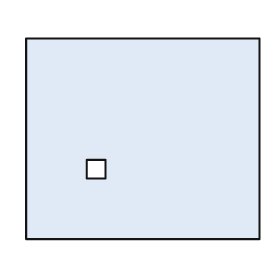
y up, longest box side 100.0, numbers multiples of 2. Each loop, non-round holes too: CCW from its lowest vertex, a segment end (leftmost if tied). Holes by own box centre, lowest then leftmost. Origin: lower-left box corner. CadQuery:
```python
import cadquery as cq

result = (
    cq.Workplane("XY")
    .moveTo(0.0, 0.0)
    .lineTo(100.0, 0.0)
    .lineTo(100.0, 86.0)
    .lineTo(0.0, 86.0)
    .close()
    .moveTo(26.0, 26.0)
    .lineTo(34.0, 26.0)
    .lineTo(34.0, 34.0)
    .lineTo(26.0, 34.0)
    .close()
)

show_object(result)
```